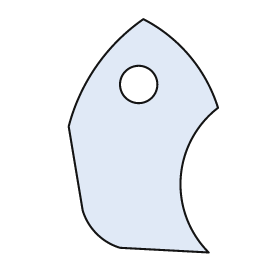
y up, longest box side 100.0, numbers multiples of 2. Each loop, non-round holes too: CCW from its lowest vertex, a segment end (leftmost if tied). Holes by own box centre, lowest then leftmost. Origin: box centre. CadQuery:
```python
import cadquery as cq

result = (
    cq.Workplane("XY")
    .moveTo(28.0, -50.0)
    .threePointArc((16.0, -18.0), (32.0, 12.0))
    .threePointArc((20.0, 34.0), (0.0, 50.0))
    .threePointArc((-20.0, 30.0), (-32.0, 4.0))
    .lineTo(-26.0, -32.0)
    .threePointArc((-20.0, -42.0), (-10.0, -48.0))
    .close()
    .moveTo(-2.0, 22.0)
    .circle(8.0)
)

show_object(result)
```